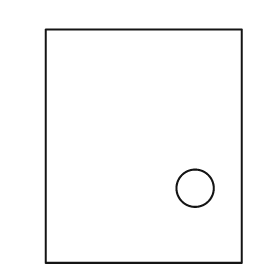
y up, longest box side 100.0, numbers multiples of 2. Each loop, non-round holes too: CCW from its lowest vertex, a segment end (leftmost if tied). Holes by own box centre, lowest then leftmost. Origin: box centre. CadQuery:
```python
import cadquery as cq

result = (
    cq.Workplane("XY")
    .moveTo(-42.0, -50.0)
    .lineTo(42.0, -50.0)
    .lineTo(42.0, 50.0)
    .lineTo(-42.0, 50.0)
    .close()
    .moveTo(22.0, -18.0)
    .circle(8.0)
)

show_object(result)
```